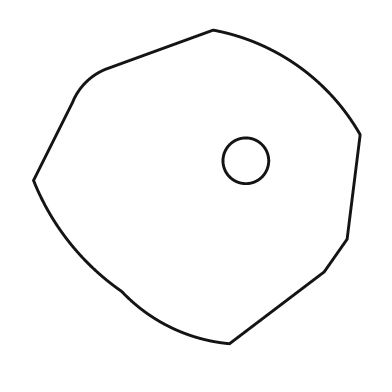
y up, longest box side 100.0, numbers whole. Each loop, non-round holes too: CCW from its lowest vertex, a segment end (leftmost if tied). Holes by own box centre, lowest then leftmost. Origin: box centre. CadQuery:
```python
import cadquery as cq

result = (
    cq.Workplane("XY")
    .moveTo(10.0, -48.0)
    .lineTo(39.0, -26.0)
    .lineTo(46.0, -16.0)
    .lineTo(50.0, 16.0)
    .threePointArc((31.0, 37.0), (5.0, 48.0))
    .lineTo(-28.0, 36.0)
    .threePointArc((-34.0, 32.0), (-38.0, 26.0))
    .lineTo(-50.0, 2.0)
    .threePointArc((-39.0, -17.0), (-23.0, -32.0))
    .threePointArc((-8.0, -43.0), (10.0, -48.0))
    .close()
    .moveTo(15.0, 8.0)
    .circle(7.0)
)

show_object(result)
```